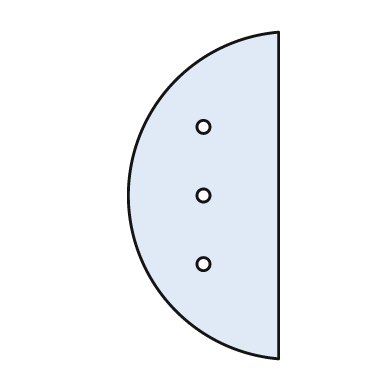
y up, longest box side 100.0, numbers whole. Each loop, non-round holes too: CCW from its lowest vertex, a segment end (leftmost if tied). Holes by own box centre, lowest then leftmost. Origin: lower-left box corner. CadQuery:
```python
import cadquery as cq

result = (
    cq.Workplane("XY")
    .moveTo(46.0, 0.0)
    .lineTo(46.0, 100.0)
    .threePointArc((0.0, 50.0), (46.0, 0.0))
    .close()
    .moveTo(23.0, 29.0)
    .circle(2.0)
    .moveTo(23.0, 50.0)
    .circle(2.0)
    .moveTo(23.0, 71.0)
    .circle(2.0)
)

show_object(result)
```